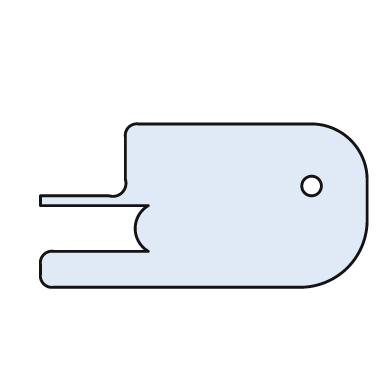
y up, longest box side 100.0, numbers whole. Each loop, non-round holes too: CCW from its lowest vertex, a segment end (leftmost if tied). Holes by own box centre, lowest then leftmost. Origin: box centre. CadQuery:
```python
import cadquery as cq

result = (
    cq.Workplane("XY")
    .moveTo(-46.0, -25.0)
    .lineTo(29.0, -25.0)
    .threePointArc((44.0, -19.0), (50.0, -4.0))
    .lineTo(50.0, 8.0)
    .threePointArc((45.0, 20.0), (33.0, 25.0))
    .lineTo(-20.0, 25.0)
    .threePointArc((-23.0, 24.0), (-24.0, 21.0))
    .lineTo(-24.0, 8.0)
    .threePointArc((-25.0, 4.0), (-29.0, 3.0))
    .lineTo(-50.0, 3.0)
    .lineTo(-50.0, 0.0)
    .lineTo(-17.0, 0.0)
    .threePointArc((-21.0, -7.0), (-17.0, -14.0))
    .lineTo(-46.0, -14.0)
    .threePointArc((-49.0, -15.0), (-50.0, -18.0))
    .lineTo(-50.0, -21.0)
    .threePointArc((-49.0, -24.0), (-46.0, -25.0))
    .close()
    .moveTo(33.0, 6.0)
    .circle(3.0)
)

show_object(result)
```